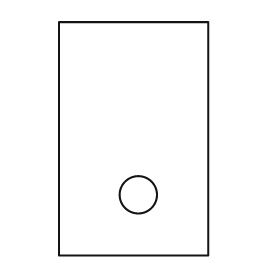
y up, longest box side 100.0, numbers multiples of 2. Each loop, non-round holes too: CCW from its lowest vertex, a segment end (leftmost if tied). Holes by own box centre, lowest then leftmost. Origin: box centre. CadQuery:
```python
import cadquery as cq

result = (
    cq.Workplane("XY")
    .moveTo(-32.0, -50.0)
    .lineTo(32.0, -50.0)
    .lineTo(32.0, 50.0)
    .lineTo(-32.0, 50.0)
    .close()
    .moveTo(2.0, -24.0)
    .circle(8.0)
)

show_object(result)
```